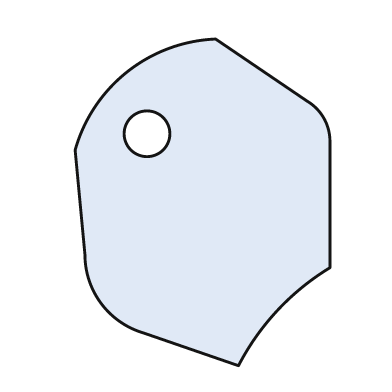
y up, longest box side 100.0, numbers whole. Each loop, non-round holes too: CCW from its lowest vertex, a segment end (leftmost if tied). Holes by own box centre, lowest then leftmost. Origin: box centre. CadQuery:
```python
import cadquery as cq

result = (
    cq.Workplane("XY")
    .moveTo(11.0, -50.0)
    .threePointArc((23.0, -33.0), (39.0, -20.0))
    .lineTo(39.0, 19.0)
    .threePointArc((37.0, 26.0), (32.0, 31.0))
    .lineTo(4.0, 50.0)
    .threePointArc((-23.0, 40.0), (-39.0, 16.0))
    .lineTo(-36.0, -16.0)
    .threePointArc((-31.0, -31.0), (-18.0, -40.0))
    .close()
    .moveTo(-17.0, 21.0)
    .circle(7.0)
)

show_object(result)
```